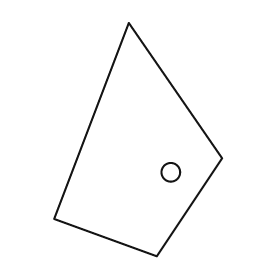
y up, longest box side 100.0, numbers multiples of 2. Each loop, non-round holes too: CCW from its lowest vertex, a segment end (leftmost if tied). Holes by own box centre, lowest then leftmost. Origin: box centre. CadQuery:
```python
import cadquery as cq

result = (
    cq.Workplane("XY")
    .moveTo(8.0, -50.0)
    .lineTo(36.0, -8.0)
    .lineTo(-4.0, 50.0)
    .lineTo(-36.0, -34.0)
    .close()
    .moveTo(14.0, -14.0)
    .circle(4.0)
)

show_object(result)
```